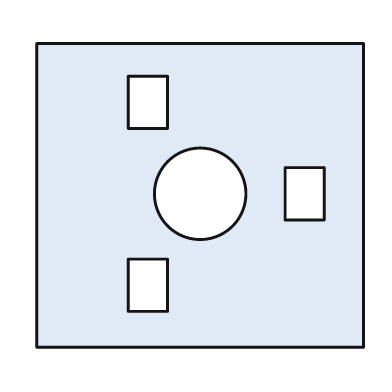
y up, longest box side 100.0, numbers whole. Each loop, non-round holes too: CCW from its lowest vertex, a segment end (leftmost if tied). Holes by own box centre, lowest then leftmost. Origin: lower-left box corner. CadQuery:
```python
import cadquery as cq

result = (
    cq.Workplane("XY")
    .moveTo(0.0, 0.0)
    .lineTo(100.0, 0.0)
    .lineTo(100.0, 93.0)
    .lineTo(0.0, 93.0)
    .close()
    .moveTo(28.0, 11.0)
    .lineTo(40.0, 11.0)
    .lineTo(40.0, 27.0)
    .lineTo(28.0, 27.0)
    .close()
    .moveTo(50.0, 47.0)
    .circle(14.0)
    .moveTo(76.0, 39.0)
    .lineTo(88.0, 39.0)
    .lineTo(88.0, 55.0)
    .lineTo(76.0, 55.0)
    .close()
    .moveTo(28.0, 67.0)
    .lineTo(40.0, 67.0)
    .lineTo(40.0, 83.0)
    .lineTo(28.0, 83.0)
    .close()
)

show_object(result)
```